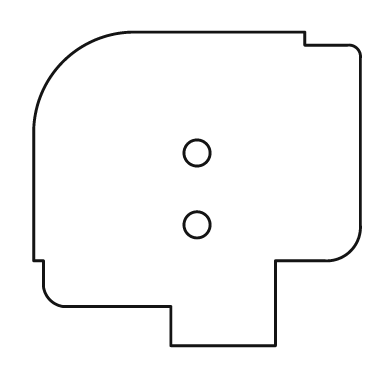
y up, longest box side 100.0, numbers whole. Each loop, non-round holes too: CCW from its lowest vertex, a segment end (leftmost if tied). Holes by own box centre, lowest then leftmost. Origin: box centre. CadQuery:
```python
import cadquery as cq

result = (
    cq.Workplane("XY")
    .moveTo(-8.0, -48.0)
    .lineTo(24.0, -48.0)
    .lineTo(24.0, -22.0)
    .lineTo(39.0, -22.0)
    .threePointArc((47.0, -19.0), (50.0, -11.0))
    .lineTo(50.0, 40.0)
    .threePointArc((49.0, 43.0), (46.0, 44.0))
    .lineTo(33.0, 44.0)
    .lineTo(33.0, 48.0)
    .lineTo(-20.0, 48.0)
    .threePointArc((-41.0, 39.0), (-50.0, 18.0))
    .lineTo(-50.0, -22.0)
    .lineTo(-47.0, -22.0)
    .lineTo(-47.0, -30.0)
    .threePointArc((-45.0, -34.0), (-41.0, -36.0))
    .lineTo(-8.0, -36.0)
    .close()
    .moveTo(0.0, -11.0)
    .circle(4.0)
    .moveTo(0.0, 11.0)
    .circle(4.0)
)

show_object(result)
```